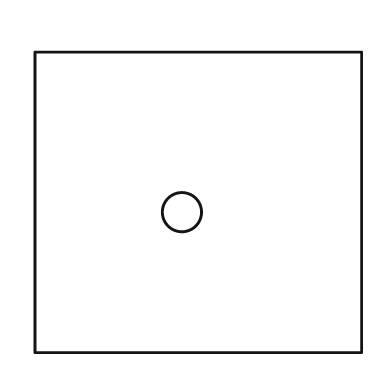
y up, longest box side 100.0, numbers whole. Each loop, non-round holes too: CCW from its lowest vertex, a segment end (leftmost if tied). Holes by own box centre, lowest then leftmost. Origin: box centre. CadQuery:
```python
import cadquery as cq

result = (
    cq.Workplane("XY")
    .moveTo(-50.0, -46.0)
    .lineTo(50.0, -46.0)
    .lineTo(50.0, 46.0)
    .lineTo(-50.0, 46.0)
    .close()
    .moveTo(-5.0, -3.0)
    .circle(6.0)
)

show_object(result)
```